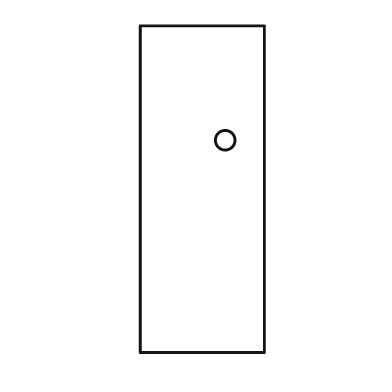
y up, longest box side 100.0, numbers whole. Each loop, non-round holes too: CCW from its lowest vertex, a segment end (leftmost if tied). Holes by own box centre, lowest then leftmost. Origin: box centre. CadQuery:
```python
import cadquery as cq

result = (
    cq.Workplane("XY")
    .moveTo(-19.0, -50.0)
    .lineTo(19.0, -50.0)
    .lineTo(19.0, 50.0)
    .lineTo(-19.0, 50.0)
    .close()
    .moveTo(7.0, 15.0)
    .circle(3.0)
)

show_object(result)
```